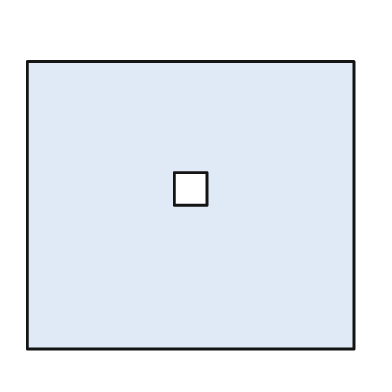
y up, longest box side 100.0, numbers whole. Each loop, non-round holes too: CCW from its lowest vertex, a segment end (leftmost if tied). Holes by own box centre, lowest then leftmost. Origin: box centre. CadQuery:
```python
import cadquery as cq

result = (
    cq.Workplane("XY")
    .moveTo(-50.0, -44.0)
    .lineTo(50.0, -44.0)
    .lineTo(50.0, 44.0)
    .lineTo(-50.0, 44.0)
    .close()
    .moveTo(-5.0, 0.0)
    .lineTo(5.0, 0.0)
    .lineTo(5.0, 10.0)
    .lineTo(-5.0, 10.0)
    .close()
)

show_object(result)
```